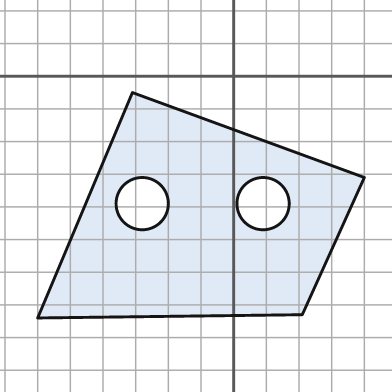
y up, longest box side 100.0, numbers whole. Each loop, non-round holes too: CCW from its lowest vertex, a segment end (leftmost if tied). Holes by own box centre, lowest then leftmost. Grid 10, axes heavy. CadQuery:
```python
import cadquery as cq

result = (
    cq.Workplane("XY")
    .moveTo(-60.0, -74.0)
    .lineTo(21.0, -73.0)
    .lineTo(40.0, -31.0)
    .lineTo(-31.0, -5.0)
    .close()
    .moveTo(-28.0, -39.0)
    .circle(8.0)
    .moveTo(9.0, -39.0)
    .circle(8.0)
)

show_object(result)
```